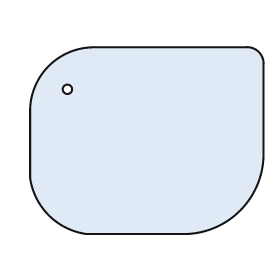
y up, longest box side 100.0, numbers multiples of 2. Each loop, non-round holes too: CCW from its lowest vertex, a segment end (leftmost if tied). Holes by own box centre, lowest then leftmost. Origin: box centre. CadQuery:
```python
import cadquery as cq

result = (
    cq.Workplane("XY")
    .moveTo(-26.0, -40.0)
    .lineTo(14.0, -40.0)
    .threePointArc((40.0, -30.0), (50.0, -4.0))
    .lineTo(50.0, 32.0)
    .threePointArc((48.0, 38.0), (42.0, 40.0))
    .lineTo(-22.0, 40.0)
    .threePointArc((-42.0, 32.0), (-50.0, 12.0))
    .lineTo(-50.0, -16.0)
    .threePointArc((-42.0, -32.0), (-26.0, -40.0))
    .close()
    .moveTo(-34.0, 22.0)
    .circle(2.0)
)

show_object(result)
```